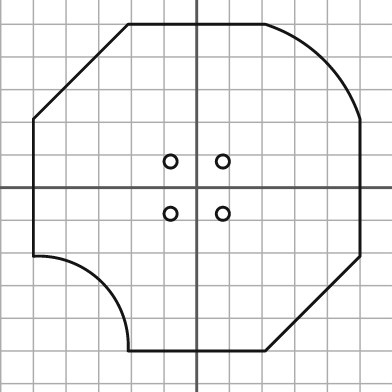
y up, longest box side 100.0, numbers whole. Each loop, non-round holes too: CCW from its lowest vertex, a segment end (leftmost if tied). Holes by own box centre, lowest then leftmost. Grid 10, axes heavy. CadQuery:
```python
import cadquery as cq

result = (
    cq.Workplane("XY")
    .moveTo(-21.0, -50.0)
    .lineTo(21.0, -50.0)
    .lineTo(50.0, -21.0)
    .lineTo(50.0, 21.0)
    .threePointArc((39.0, 39.0), (21.0, 50.0))
    .lineTo(-21.0, 50.0)
    .lineTo(-50.0, 21.0)
    .lineTo(-50.0, -21.0)
    .threePointArc((-29.0, -29.0), (-21.0, -50.0))
    .close()
    .moveTo(-8.0, -8.0)
    .circle(2.0)
    .moveTo(8.0, -8.0)
    .circle(2.0)
    .moveTo(-8.0, 8.0)
    .circle(2.0)
    .moveTo(8.0, 8.0)
    .circle(2.0)
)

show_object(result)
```